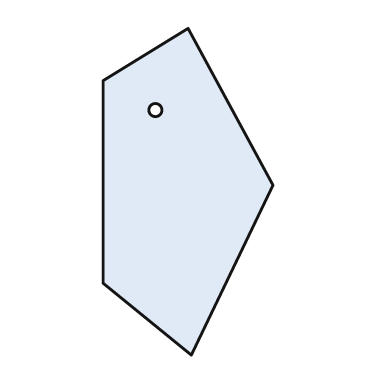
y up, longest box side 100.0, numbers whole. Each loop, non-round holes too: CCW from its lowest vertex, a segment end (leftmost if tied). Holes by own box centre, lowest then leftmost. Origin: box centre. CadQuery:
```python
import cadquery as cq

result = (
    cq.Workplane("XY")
    .moveTo(1.0, -50.0)
    .lineTo(26.0, 2.0)
    .lineTo(0.0, 50.0)
    .lineTo(-26.0, 34.0)
    .lineTo(-26.0, -28.0)
    .close()
    .moveTo(-10.0, 25.0)
    .circle(2.0)
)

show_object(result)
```